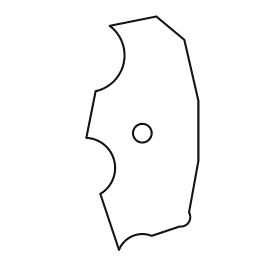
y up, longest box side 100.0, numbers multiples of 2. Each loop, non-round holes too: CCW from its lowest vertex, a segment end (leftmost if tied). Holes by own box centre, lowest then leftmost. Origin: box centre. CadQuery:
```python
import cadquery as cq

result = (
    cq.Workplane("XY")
    .moveTo(-10.0, -50.0)
    .threePointArc((-4.0, -44.0), (4.0, -44.0))
    .lineTo(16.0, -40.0)
    .threePointArc((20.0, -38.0), (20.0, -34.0))
    .lineTo(24.0, -12.0)
    .lineTo(24.0, 14.0)
    .lineTo(18.0, 40.0)
    .lineTo(6.0, 50.0)
    .lineTo(-14.0, 46.0)
    .threePointArc((-8.0, 30.0), (-20.0, 18.0))
    .lineTo(-24.0, -2.0)
    .threePointArc((-12.0, -12.0), (-18.0, -26.0))
    .close()
    .moveTo(0.0, 0.0)
    .circle(4.0)
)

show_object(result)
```